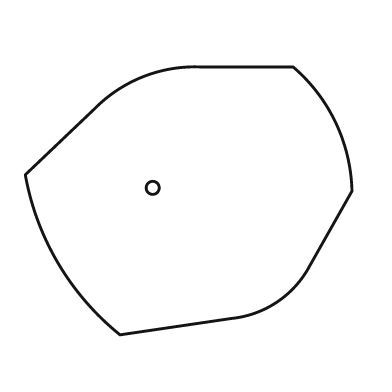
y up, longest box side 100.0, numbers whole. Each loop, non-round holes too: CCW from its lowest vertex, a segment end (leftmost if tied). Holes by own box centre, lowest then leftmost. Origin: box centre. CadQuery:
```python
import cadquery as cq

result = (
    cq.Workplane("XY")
    .moveTo(-21.0, -41.0)
    .lineTo(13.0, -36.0)
    .threePointArc((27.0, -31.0), (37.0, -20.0))
    .lineTo(50.0, 3.0)
    .threePointArc((45.0, 24.0), (32.0, 41.0))
    .lineTo(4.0, 41.0)
    .threePointArc((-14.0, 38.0), (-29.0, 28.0))
    .lineTo(-50.0, 8.0)
    .threePointArc((-40.0, -19.0), (-21.0, -41.0))
    .close()
    .moveTo(-11.0, 4.0)
    .circle(2.0)
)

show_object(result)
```